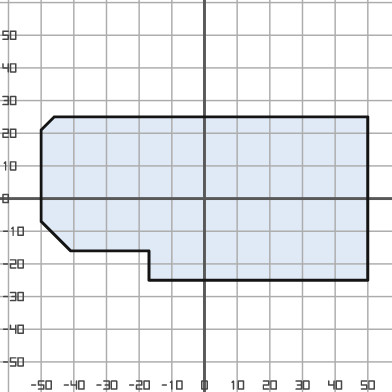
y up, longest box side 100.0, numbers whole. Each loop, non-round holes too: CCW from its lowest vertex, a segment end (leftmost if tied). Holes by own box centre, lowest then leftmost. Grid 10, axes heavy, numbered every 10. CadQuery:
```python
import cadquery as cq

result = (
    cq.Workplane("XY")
    .moveTo(-17.0, -25.0)
    .lineTo(50.0, -25.0)
    .lineTo(50.0, 25.0)
    .lineTo(-46.0, 25.0)
    .lineTo(-50.0, 21.0)
    .lineTo(-50.0, -7.0)
    .lineTo(-41.0, -16.0)
    .lineTo(-17.0, -16.0)
    .close()
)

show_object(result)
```